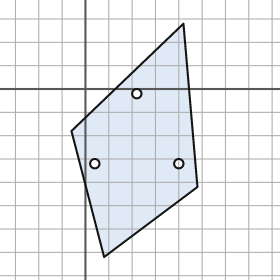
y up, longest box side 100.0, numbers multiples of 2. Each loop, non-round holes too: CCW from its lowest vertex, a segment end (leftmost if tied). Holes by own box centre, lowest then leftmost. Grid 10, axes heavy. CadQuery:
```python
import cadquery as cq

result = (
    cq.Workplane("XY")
    .moveTo(8.0, -72.0)
    .lineTo(48.0, -42.0)
    .lineTo(42.0, 28.0)
    .lineTo(-6.0, -18.0)
    .close()
    .moveTo(4.0, -32.0)
    .circle(2.0)
    .moveTo(40.0, -32.0)
    .circle(2.0)
    .moveTo(22.0, -2.0)
    .circle(2.0)
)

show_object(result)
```